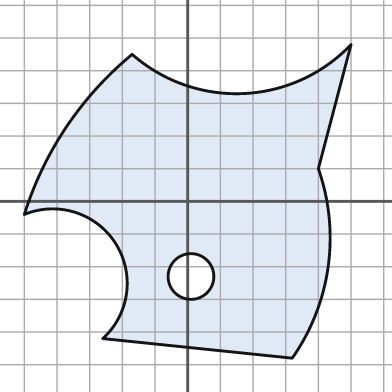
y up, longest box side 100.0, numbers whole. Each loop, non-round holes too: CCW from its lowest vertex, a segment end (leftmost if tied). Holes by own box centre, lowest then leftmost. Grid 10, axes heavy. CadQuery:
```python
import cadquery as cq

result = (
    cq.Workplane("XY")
    .moveTo(32.0, -48.0)
    .threePointArc((43.0, -20.0), (40.0, 10.0))
    .lineTo(50.0, 48.0)
    .threePointArc((17.0, 33.0), (-17.0, 45.0))
    .threePointArc((-37.0, 23.0), (-50.0, -4.0))
    .threePointArc((-22.0, -13.0), (-26.0, -42.0))
    .close()
    .moveTo(1.0, -23.0)
    .circle(7.0)
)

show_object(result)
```